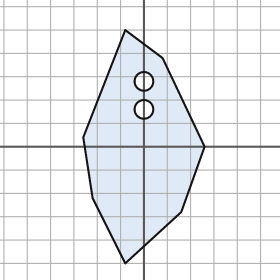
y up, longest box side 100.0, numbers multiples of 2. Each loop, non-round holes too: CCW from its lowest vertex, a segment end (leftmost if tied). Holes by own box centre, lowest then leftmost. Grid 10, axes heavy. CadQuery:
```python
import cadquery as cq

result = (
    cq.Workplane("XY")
    .moveTo(-8.0, -50.0)
    .lineTo(16.0, -28.0)
    .lineTo(26.0, 0.0)
    .lineTo(8.0, 38.0)
    .lineTo(-8.0, 50.0)
    .lineTo(-26.0, 4.0)
    .lineTo(-22.0, -22.0)
    .close()
    .moveTo(0.0, 16.0)
    .circle(4.0)
    .moveTo(0.0, 28.0)
    .circle(4.0)
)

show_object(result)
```